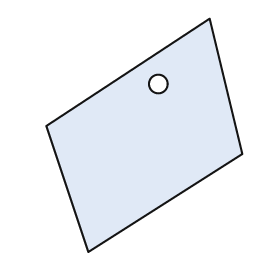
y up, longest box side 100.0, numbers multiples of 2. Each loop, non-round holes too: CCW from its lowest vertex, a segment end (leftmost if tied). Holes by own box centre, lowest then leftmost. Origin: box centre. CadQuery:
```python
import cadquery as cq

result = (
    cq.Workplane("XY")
    .moveTo(-24.0, -50.0)
    .lineTo(42.0, -8.0)
    .lineTo(28.0, 50.0)
    .lineTo(-42.0, 4.0)
    .close()
    .moveTo(6.0, 22.0)
    .circle(4.0)
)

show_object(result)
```